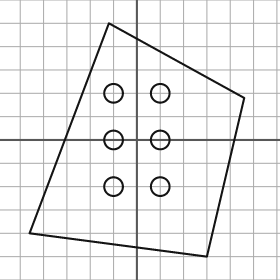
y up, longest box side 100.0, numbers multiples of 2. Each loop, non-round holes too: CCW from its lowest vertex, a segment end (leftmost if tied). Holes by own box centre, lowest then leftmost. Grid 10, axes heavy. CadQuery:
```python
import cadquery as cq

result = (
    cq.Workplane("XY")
    .moveTo(30.0, -50.0)
    .lineTo(46.0, 18.0)
    .lineTo(-12.0, 50.0)
    .lineTo(-46.0, -40.0)
    .close()
    .moveTo(-10.0, -20.0)
    .circle(4.0)
    .moveTo(10.0, -20.0)
    .circle(4.0)
    .moveTo(-10.0, 0.0)
    .circle(4.0)
    .moveTo(10.0, 0.0)
    .circle(4.0)
    .moveTo(-10.0, 20.0)
    .circle(4.0)
    .moveTo(10.0, 20.0)
    .circle(4.0)
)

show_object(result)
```